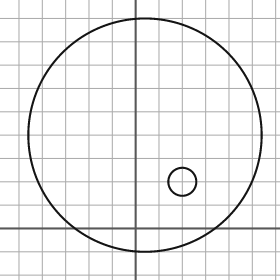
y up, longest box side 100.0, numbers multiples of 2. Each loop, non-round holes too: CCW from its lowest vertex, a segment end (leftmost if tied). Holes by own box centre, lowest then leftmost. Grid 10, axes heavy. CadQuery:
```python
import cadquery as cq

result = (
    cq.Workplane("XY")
    .moveTo(4.0, 40.0)
    .circle(50.0)
    .moveTo(20.0, 20.0)
    .circle(6.0)
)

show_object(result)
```